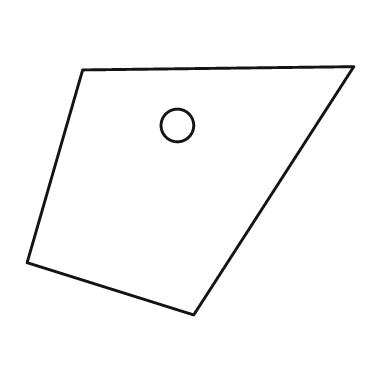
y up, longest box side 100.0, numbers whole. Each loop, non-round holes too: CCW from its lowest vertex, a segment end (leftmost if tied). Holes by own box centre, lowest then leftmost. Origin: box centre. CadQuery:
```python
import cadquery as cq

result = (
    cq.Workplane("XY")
    .moveTo(1.0, -38.0)
    .lineTo(50.0, 38.0)
    .lineTo(-33.0, 37.0)
    .lineTo(-50.0, -22.0)
    .close()
    .moveTo(-4.0, 20.0)
    .circle(5.0)
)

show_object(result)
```